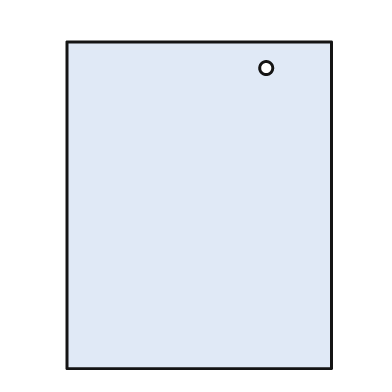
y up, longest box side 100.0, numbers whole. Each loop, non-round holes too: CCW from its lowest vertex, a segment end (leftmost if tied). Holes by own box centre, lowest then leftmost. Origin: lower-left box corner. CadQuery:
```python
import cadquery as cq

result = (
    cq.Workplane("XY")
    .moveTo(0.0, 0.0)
    .lineTo(81.0, 0.0)
    .lineTo(81.0, 100.0)
    .lineTo(0.0, 100.0)
    .close()
    .moveTo(61.0, 92.0)
    .circle(2.0)
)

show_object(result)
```